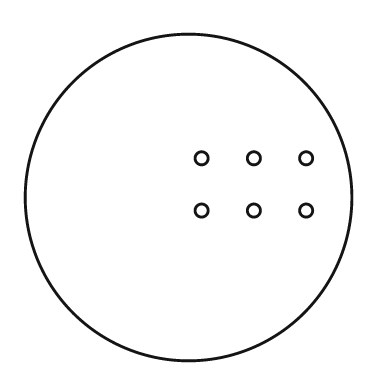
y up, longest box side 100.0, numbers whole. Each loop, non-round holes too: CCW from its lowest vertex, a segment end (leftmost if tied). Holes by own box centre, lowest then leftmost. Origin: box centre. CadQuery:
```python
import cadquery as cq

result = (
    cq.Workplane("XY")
    .moveTo(0.0, 0.0)
    .circle(50.0)
    .moveTo(4.0, -4.0)
    .circle(2.0)
    .moveTo(20.0, -4.0)
    .circle(2.0)
    .moveTo(36.0, -4.0)
    .circle(2.0)
    .moveTo(4.0, 12.0)
    .circle(2.0)
    .moveTo(20.0, 12.0)
    .circle(2.0)
    .moveTo(36.0, 12.0)
    .circle(2.0)
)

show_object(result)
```